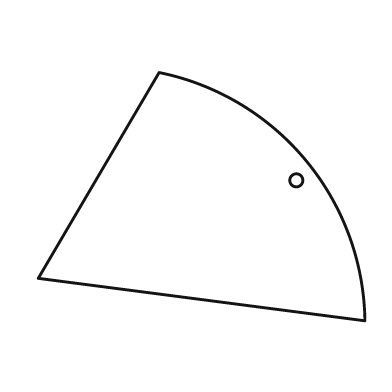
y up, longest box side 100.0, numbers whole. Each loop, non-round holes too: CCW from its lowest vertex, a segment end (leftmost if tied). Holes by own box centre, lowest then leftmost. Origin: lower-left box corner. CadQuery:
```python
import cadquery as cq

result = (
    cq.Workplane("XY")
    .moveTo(100.0, 0.0)
    .threePointArc((82.0, 49.0), (37.0, 76.0))
    .lineTo(0.0, 13.0)
    .close()
    .moveTo(79.0, 43.0)
    .circle(2.0)
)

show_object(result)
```